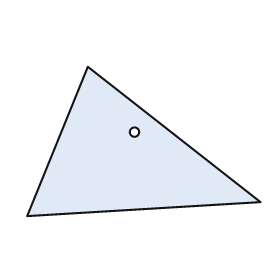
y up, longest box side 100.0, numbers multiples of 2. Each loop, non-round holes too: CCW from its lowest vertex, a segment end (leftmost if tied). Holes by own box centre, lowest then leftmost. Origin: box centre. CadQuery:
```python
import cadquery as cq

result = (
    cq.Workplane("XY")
    .moveTo(-50.0, -32.0)
    .lineTo(50.0, -26.0)
    .lineTo(-24.0, 32.0)
    .close()
    .moveTo(-4.0, 4.0)
    .circle(2.0)
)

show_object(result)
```